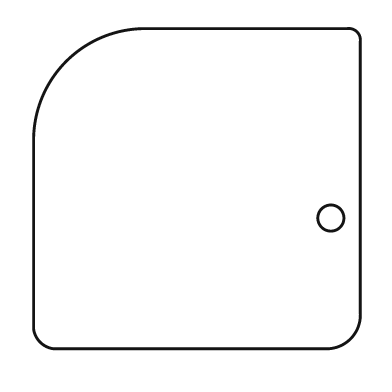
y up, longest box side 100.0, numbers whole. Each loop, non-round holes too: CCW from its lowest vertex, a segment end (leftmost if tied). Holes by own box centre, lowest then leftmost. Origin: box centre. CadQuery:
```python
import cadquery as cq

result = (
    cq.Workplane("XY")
    .moveTo(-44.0, -49.0)
    .lineTo(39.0, -49.0)
    .threePointArc((47.0, -46.0), (50.0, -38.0))
    .lineTo(50.0, 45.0)
    .threePointArc((49.0, 48.0), (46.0, 49.0))
    .lineTo(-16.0, 49.0)
    .threePointArc((-40.0, 39.0), (-50.0, 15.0))
    .lineTo(-50.0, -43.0)
    .threePointArc((-48.0, -47.0), (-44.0, -49.0))
    .close()
    .moveTo(41.0, -9.0)
    .circle(4.0)
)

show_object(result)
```